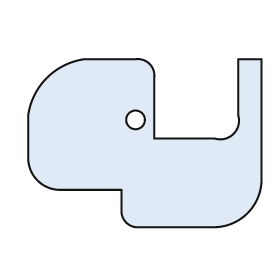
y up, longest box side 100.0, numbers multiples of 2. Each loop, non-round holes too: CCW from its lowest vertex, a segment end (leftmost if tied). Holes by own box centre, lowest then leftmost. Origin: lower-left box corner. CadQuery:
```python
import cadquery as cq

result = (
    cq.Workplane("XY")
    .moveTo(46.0, 0.0)
    .lineTo(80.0, 0.0)
    .threePointArc((94.0, 6.0), (100.0, 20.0))
    .lineTo(100.0, 72.0)
    .lineTo(90.0, 72.0)
    .lineTo(90.0, 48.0)
    .threePointArc((88.0, 40.0), (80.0, 38.0))
    .lineTo(54.0, 38.0)
    .lineTo(54.0, 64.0)
    .threePointArc((52.0, 70.0), (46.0, 72.0))
    .lineTo(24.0, 72.0)
    .threePointArc((8.0, 64.0), (0.0, 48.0))
    .lineTo(0.0, 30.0)
    .threePointArc((4.0, 20.0), (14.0, 16.0))
    .lineTo(40.0, 16.0)
    .lineTo(40.0, 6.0)
    .threePointArc((42.0, 2.0), (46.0, 0.0))
    .close()
    .moveTo(46.0, 46.0)
    .circle(4.0)
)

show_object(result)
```